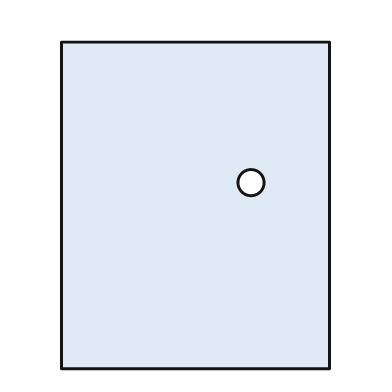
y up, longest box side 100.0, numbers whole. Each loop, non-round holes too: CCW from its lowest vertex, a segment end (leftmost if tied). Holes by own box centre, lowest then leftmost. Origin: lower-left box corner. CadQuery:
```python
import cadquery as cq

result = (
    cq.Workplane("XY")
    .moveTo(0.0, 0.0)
    .lineTo(82.0, 0.0)
    .lineTo(82.0, 100.0)
    .lineTo(0.0, 100.0)
    .close()
    .moveTo(58.0, 57.0)
    .circle(4.0)
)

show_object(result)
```